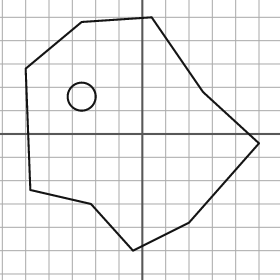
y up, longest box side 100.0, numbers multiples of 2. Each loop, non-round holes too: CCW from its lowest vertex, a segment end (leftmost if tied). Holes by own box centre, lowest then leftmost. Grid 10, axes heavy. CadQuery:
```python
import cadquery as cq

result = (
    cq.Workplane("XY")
    .moveTo(-4.0, -50.0)
    .lineTo(20.0, -38.0)
    .lineTo(50.0, -4.0)
    .lineTo(26.0, 18.0)
    .lineTo(4.0, 50.0)
    .lineTo(-26.0, 48.0)
    .lineTo(-50.0, 28.0)
    .lineTo(-48.0, -24.0)
    .lineTo(-22.0, -30.0)
    .close()
    .moveTo(-26.0, 16.0)
    .circle(6.0)
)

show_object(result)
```